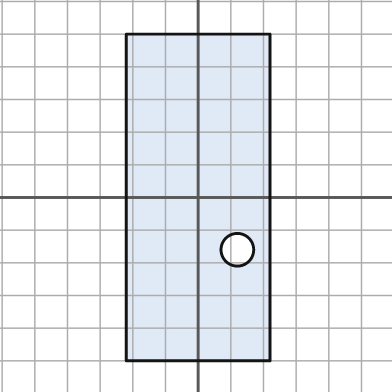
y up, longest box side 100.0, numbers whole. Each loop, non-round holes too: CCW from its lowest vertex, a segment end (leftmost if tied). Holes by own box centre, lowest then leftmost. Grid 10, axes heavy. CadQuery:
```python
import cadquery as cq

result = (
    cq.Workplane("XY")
    .moveTo(-22.0, -50.0)
    .lineTo(22.0, -50.0)
    .lineTo(22.0, 50.0)
    .lineTo(-22.0, 50.0)
    .close()
    .moveTo(12.0, -16.0)
    .circle(5.0)
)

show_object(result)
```